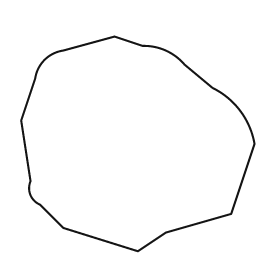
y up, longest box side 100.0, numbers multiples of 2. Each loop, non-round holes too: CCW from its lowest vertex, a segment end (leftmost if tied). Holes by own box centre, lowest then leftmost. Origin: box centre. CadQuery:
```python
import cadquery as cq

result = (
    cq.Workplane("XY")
    .moveTo(0.0, -46.0)
    .lineTo(12.0, -38.0)
    .lineTo(40.0, -30.0)
    .lineTo(50.0, 0.0)
    .threePointArc((44.0, 14.0), (32.0, 24.0))
    .lineTo(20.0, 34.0)
    .threePointArc((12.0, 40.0), (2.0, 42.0))
    .lineTo(-10.0, 46.0)
    .lineTo(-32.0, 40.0)
    .threePointArc((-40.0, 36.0), (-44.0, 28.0))
    .lineTo(-50.0, 10.0)
    .lineTo(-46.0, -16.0)
    .threePointArc((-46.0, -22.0), (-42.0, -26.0))
    .lineTo(-32.0, -36.0)
    .close()
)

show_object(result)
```